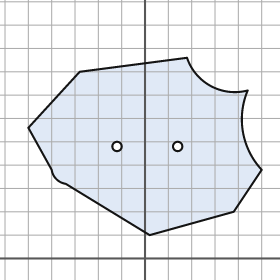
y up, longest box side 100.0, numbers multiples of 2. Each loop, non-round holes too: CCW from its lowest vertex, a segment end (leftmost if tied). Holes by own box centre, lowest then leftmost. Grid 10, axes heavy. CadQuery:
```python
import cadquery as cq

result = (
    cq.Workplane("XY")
    .moveTo(2.0, 10.0)
    .lineTo(38.0, 20.0)
    .lineTo(50.0, 38.0)
    .threePointArc((42.0, 54.0), (44.0, 72.0))
    .threePointArc((28.0, 74.0), (18.0, 86.0))
    .lineTo(-28.0, 80.0)
    .lineTo(-50.0, 56.0)
    .lineTo(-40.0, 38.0)
    .threePointArc((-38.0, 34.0), (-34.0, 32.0))
    .close()
    .moveTo(-12.0, 48.0)
    .circle(2.0)
    .moveTo(14.0, 48.0)
    .circle(2.0)
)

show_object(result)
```